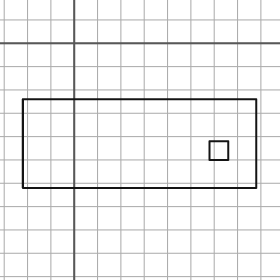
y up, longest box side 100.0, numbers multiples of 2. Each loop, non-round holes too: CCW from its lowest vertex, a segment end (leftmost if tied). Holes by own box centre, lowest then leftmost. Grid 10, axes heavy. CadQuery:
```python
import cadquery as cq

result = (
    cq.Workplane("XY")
    .moveTo(-22.0, -62.0)
    .lineTo(78.0, -62.0)
    .lineTo(78.0, -24.0)
    .lineTo(-22.0, -24.0)
    .close()
    .moveTo(58.0, -50.0)
    .lineTo(66.0, -50.0)
    .lineTo(66.0, -42.0)
    .lineTo(58.0, -42.0)
    .close()
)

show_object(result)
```